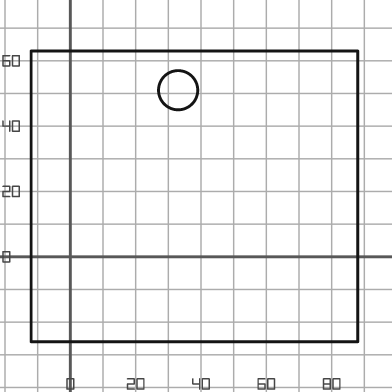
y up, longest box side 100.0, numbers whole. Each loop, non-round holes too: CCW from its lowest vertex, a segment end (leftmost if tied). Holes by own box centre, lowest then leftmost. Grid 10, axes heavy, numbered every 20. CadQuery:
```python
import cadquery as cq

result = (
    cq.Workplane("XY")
    .moveTo(-12.0, -26.0)
    .lineTo(88.0, -26.0)
    .lineTo(88.0, 63.0)
    .lineTo(-12.0, 63.0)
    .close()
    .moveTo(33.0, 51.0)
    .circle(6.0)
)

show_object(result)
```